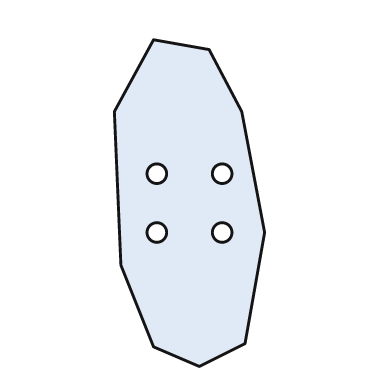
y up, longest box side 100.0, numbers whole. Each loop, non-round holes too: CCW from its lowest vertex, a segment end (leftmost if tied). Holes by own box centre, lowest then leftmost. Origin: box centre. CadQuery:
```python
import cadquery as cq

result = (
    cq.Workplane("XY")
    .moveTo(3.0, -50.0)
    .lineTo(17.0, -43.0)
    .lineTo(23.0, -9.0)
    .lineTo(16.0, 28.0)
    .lineTo(6.0, 47.0)
    .lineTo(-11.0, 50.0)
    .lineTo(-23.0, 28.0)
    .lineTo(-21.0, -19.0)
    .lineTo(-11.0, -44.0)
    .close()
    .moveTo(-10.0, -9.0)
    .circle(3.0)
    .moveTo(10.0, -9.0)
    .circle(3.0)
    .moveTo(-10.0, 9.0)
    .circle(3.0)
    .moveTo(10.0, 9.0)
    .circle(3.0)
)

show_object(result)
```